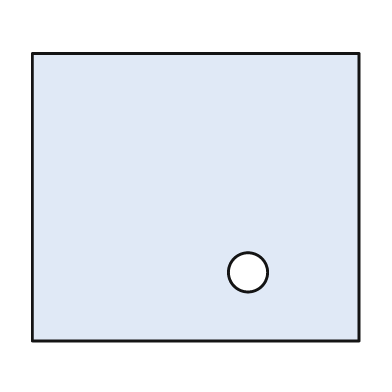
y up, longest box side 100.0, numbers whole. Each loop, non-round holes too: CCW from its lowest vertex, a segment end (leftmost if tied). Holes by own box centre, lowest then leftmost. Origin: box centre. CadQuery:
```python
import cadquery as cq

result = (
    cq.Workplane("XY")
    .moveTo(-50.0, -44.0)
    .lineTo(50.0, -44.0)
    .lineTo(50.0, 44.0)
    .lineTo(-50.0, 44.0)
    .close()
    .moveTo(16.0, -23.0)
    .circle(6.0)
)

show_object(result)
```